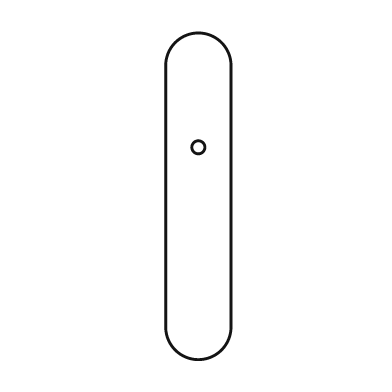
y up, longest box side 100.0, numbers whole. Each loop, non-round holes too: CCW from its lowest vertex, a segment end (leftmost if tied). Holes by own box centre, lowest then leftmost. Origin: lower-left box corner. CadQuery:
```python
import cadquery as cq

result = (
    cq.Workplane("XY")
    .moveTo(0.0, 10.0)
    .threePointArc((10.0, 0.0), (20.0, 10.0))
    .lineTo(20.0, 90.0)
    .threePointArc((10.0, 100.0), (0.0, 90.0))
    .close()
    .moveTo(10.0, 65.0)
    .circle(2.0)
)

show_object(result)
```